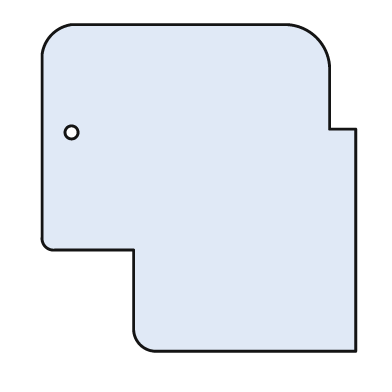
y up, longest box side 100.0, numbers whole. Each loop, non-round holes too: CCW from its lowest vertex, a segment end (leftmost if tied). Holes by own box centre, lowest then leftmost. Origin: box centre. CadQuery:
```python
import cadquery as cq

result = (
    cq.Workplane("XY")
    .moveTo(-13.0, -50.0)
    .lineTo(48.0, -50.0)
    .lineTo(48.0, 18.0)
    .lineTo(40.0, 18.0)
    .lineTo(40.0, 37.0)
    .threePointArc((36.0, 46.0), (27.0, 50.0))
    .lineTo(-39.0, 50.0)
    .threePointArc((-45.0, 47.0), (-48.0, 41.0))
    .lineTo(-48.0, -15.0)
    .threePointArc((-47.0, -18.0), (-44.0, -19.0))
    .lineTo(-20.0, -19.0)
    .lineTo(-20.0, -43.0)
    .threePointArc((-18.0, -48.0), (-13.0, -50.0))
    .close()
    .moveTo(-39.0, 17.0)
    .circle(2.0)
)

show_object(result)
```